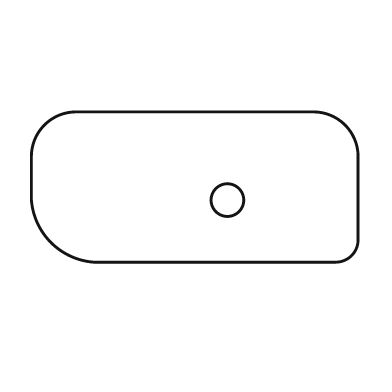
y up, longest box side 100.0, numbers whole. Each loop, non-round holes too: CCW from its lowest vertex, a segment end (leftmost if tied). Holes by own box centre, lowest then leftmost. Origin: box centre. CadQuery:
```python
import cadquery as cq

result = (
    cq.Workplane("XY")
    .moveTo(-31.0, -23.0)
    .lineTo(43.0, -23.0)
    .threePointArc((48.0, -21.0), (50.0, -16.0))
    .lineTo(50.0, 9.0)
    .threePointArc((46.0, 19.0), (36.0, 23.0))
    .lineTo(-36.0, 23.0)
    .threePointArc((-46.0, 19.0), (-50.0, 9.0))
    .lineTo(-50.0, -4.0)
    .threePointArc((-44.0, -17.0), (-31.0, -23.0))
    .close()
    .moveTo(10.0, -4.0)
    .circle(5.0)
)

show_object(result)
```